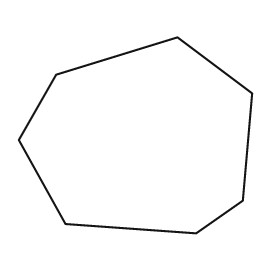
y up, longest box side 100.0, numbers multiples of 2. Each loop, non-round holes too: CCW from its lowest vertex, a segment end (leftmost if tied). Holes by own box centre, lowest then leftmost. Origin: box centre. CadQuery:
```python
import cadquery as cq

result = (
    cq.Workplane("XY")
    .moveTo(26.0, -42.0)
    .lineTo(46.0, -28.0)
    .lineTo(50.0, 18.0)
    .lineTo(18.0, 42.0)
    .lineTo(-34.0, 26.0)
    .lineTo(-50.0, -2.0)
    .lineTo(-30.0, -38.0)
    .close()
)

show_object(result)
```